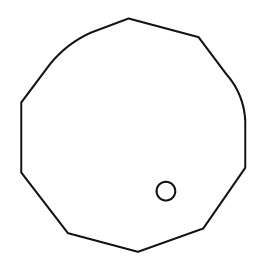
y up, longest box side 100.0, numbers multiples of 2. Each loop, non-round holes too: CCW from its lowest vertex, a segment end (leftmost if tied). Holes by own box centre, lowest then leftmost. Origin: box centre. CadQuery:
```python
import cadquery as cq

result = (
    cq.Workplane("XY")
    .moveTo(2.0, -50.0)
    .lineTo(30.0, -40.0)
    .lineTo(48.0, -14.0)
    .lineTo(48.0, 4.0)
    .threePointArc((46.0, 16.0), (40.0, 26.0))
    .lineTo(28.0, 42.0)
    .lineTo(-2.0, 50.0)
    .lineTo(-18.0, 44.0)
    .threePointArc((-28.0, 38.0), (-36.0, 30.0))
    .lineTo(-48.0, 14.0)
    .lineTo(-48.0, -16.0)
    .lineTo(-28.0, -42.0)
    .close()
    .moveTo(14.0, -24.0)
    .circle(4.0)
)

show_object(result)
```